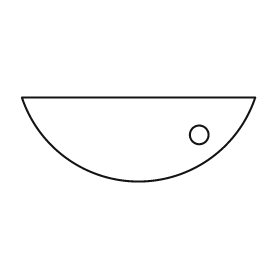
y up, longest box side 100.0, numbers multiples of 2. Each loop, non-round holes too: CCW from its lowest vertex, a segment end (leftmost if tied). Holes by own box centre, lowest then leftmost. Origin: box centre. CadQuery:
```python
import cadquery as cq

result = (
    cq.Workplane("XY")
    .moveTo(-50.0, 18.0)
    .threePointArc((0.0, -18.0), (50.0, 18.0))
    .close()
    .moveTo(26.0, 2.0)
    .circle(4.0)
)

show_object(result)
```